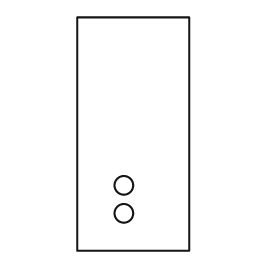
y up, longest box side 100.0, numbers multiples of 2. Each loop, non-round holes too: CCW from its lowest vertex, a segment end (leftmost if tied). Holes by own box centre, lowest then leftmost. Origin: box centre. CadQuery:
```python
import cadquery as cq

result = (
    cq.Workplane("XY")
    .moveTo(-24.0, -50.0)
    .lineTo(24.0, -50.0)
    .lineTo(24.0, 50.0)
    .lineTo(-24.0, 50.0)
    .close()
    .moveTo(-4.0, -34.0)
    .circle(4.0)
    .moveTo(-4.0, -22.0)
    .circle(4.0)
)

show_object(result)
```